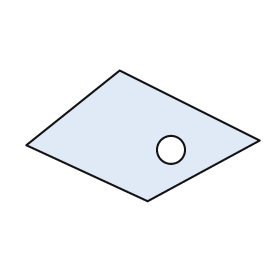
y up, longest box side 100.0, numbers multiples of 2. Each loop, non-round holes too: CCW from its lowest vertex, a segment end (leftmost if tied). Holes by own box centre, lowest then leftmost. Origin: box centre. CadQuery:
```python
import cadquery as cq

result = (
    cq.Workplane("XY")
    .moveTo(2.0, -28.0)
    .lineTo(50.0, -2.0)
    .lineTo(-10.0, 28.0)
    .lineTo(-50.0, -4.0)
    .close()
    .moveTo(12.0, -6.0)
    .circle(6.0)
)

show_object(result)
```